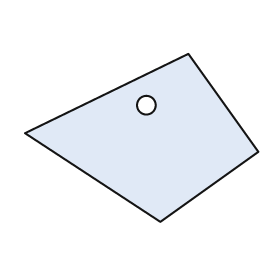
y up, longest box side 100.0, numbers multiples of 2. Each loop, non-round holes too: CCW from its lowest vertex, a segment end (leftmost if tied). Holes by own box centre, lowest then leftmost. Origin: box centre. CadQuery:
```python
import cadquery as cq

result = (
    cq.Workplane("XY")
    .moveTo(8.0, -36.0)
    .lineTo(50.0, -6.0)
    .lineTo(20.0, 36.0)
    .lineTo(-50.0, 2.0)
    .close()
    .moveTo(2.0, 14.0)
    .circle(4.0)
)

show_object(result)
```